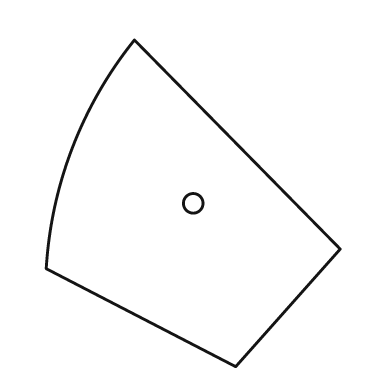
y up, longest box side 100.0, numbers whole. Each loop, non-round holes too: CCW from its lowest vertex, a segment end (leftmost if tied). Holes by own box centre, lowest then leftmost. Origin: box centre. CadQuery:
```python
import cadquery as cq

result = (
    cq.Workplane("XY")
    .moveTo(13.0, -50.0)
    .lineTo(45.0, -14.0)
    .lineTo(-18.0, 50.0)
    .threePointArc((-37.0, 17.0), (-45.0, -20.0))
    .close()
    .moveTo(0.0, 0.0)
    .circle(3.0)
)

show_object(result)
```